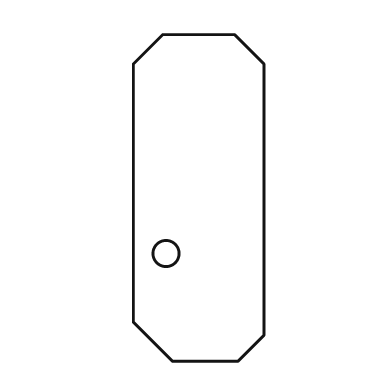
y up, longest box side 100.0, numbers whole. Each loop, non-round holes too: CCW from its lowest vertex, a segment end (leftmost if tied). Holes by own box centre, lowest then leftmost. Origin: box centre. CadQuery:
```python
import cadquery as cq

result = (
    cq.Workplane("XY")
    .moveTo(-8.0, -50.0)
    .lineTo(12.0, -50.0)
    .lineTo(20.0, -42.0)
    .lineTo(20.0, 41.0)
    .lineTo(11.0, 50.0)
    .lineTo(-11.0, 50.0)
    .lineTo(-20.0, 41.0)
    .lineTo(-20.0, -38.0)
    .close()
    .moveTo(-10.0, -17.0)
    .circle(4.0)
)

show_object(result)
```